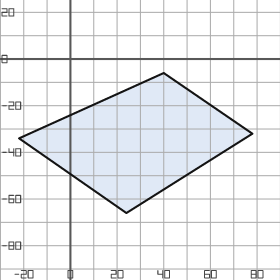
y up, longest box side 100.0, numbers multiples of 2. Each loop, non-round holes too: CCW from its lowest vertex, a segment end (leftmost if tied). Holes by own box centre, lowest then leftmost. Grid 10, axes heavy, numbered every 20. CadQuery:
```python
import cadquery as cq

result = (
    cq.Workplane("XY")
    .moveTo(24.0, -66.0)
    .lineTo(78.0, -32.0)
    .lineTo(40.0, -6.0)
    .lineTo(-22.0, -34.0)
    .close()
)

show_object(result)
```